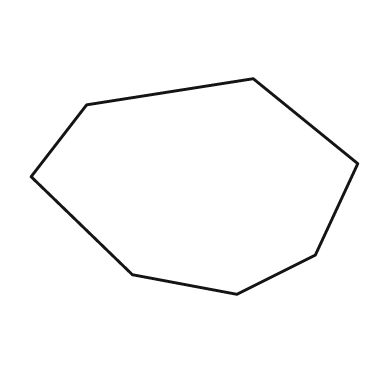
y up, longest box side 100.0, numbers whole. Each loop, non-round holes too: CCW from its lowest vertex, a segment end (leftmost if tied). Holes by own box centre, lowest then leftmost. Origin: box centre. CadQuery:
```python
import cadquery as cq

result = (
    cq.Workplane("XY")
    .moveTo(13.0, -33.0)
    .lineTo(37.0, -21.0)
    .lineTo(50.0, 7.0)
    .lineTo(18.0, 33.0)
    .lineTo(-33.0, 25.0)
    .lineTo(-50.0, 3.0)
    .lineTo(-19.0, -27.0)
    .close()
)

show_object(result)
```